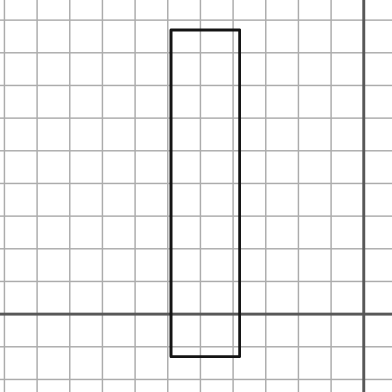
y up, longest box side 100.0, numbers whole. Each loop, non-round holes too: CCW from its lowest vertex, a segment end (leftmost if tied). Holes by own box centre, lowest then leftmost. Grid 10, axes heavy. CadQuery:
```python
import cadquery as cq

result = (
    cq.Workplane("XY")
    .moveTo(-59.0, -13.0)
    .lineTo(-38.0, -13.0)
    .lineTo(-38.0, 87.0)
    .lineTo(-59.0, 87.0)
    .close()
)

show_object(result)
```